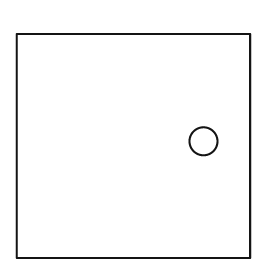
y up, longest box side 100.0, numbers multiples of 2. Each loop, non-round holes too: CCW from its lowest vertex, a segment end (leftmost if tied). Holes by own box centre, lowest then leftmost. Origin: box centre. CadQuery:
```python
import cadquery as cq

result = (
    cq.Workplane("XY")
    .moveTo(-50.0, -48.0)
    .lineTo(50.0, -48.0)
    .lineTo(50.0, 48.0)
    .lineTo(-50.0, 48.0)
    .close()
    .moveTo(30.0, 2.0)
    .circle(6.0)
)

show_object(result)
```